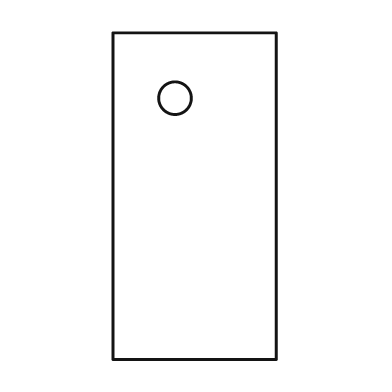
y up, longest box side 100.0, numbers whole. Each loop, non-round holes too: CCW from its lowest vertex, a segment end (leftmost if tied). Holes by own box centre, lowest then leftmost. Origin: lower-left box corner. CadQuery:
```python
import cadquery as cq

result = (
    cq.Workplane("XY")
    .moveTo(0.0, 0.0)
    .lineTo(50.0, 0.0)
    .lineTo(50.0, 100.0)
    .lineTo(0.0, 100.0)
    .close()
    .moveTo(19.0, 80.0)
    .circle(5.0)
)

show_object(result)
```